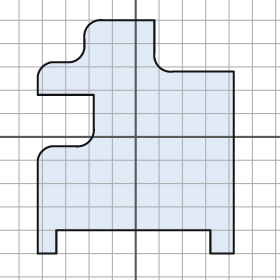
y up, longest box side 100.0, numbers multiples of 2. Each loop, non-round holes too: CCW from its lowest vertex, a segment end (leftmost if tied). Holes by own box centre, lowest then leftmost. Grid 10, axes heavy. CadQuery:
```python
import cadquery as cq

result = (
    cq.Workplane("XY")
    .moveTo(-42.0, -50.0)
    .lineTo(-34.0, -50.0)
    .lineTo(-34.0, -40.0)
    .lineTo(32.0, -40.0)
    .lineTo(32.0, -50.0)
    .lineTo(42.0, -50.0)
    .lineTo(42.0, 28.0)
    .lineTo(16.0, 28.0)
    .threePointArc((10.0, 30.0), (8.0, 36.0))
    .lineTo(8.0, 50.0)
    .lineTo(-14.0, 50.0)
    .threePointArc((-20.0, 48.0), (-22.0, 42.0))
    .lineTo(-22.0, 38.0)
    .threePointArc((-24.0, 34.0), (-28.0, 32.0))
    .lineTo(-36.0, 32.0)
    .threePointArc((-40.0, 30.0), (-42.0, 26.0))
    .lineTo(-42.0, 18.0)
    .lineTo(-18.0, 18.0)
    .lineTo(-18.0, 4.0)
    .threePointArc((-20.0, -2.0), (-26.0, -4.0))
    .lineTo(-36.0, -4.0)
    .threePointArc((-40.0, -6.0), (-42.0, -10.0))
    .close()
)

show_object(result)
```